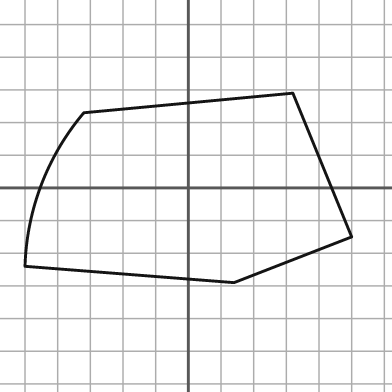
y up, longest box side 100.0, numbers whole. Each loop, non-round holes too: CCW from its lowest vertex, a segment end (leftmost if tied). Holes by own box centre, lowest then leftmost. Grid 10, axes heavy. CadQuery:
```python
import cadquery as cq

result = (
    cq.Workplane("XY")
    .moveTo(14.0, -29.0)
    .lineTo(50.0, -15.0)
    .lineTo(32.0, 29.0)
    .lineTo(-32.0, 23.0)
    .threePointArc((-45.0, 1.0), (-50.0, -24.0))
    .close()
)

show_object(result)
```